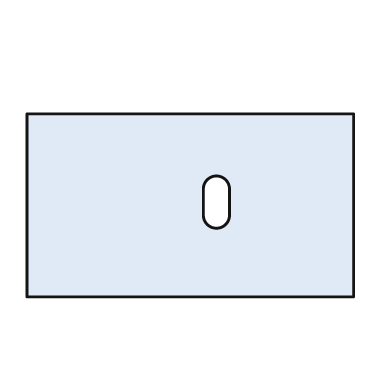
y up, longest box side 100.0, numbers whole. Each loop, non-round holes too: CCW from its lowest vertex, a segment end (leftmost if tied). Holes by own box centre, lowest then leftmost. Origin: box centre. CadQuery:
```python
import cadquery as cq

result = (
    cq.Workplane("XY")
    .moveTo(-50.0, -28.0)
    .lineTo(50.0, -28.0)
    .lineTo(50.0, 28.0)
    .lineTo(-50.0, 28.0)
    .close()
    .moveTo(4.0, -3.0)
    .threePointArc((8.0, -7.0), (12.0, -3.0))
    .lineTo(12.0, 5.0)
    .threePointArc((8.0, 9.0), (4.0, 5.0))
    .close()
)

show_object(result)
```